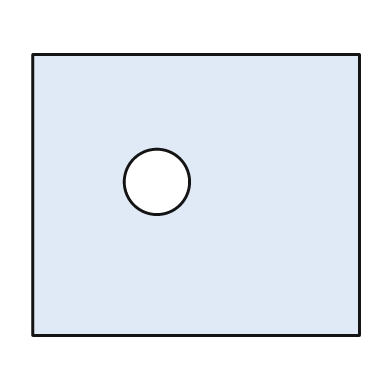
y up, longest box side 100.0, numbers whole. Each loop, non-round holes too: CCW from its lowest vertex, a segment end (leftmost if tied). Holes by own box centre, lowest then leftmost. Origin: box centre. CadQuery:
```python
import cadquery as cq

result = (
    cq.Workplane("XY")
    .moveTo(-50.0, -43.0)
    .lineTo(50.0, -43.0)
    .lineTo(50.0, 43.0)
    .lineTo(-50.0, 43.0)
    .close()
    .moveTo(-12.0, 4.0)
    .circle(10.0)
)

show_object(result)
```